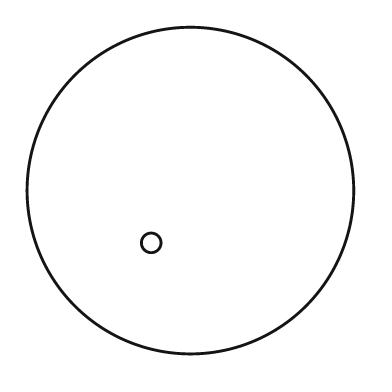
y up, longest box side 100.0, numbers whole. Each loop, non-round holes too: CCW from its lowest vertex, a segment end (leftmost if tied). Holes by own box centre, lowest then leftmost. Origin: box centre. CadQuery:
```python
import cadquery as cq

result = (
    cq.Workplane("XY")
    .moveTo(0.0, 0.0)
    .circle(50.0)
    .moveTo(-12.0, -16.0)
    .circle(3.0)
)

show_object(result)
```